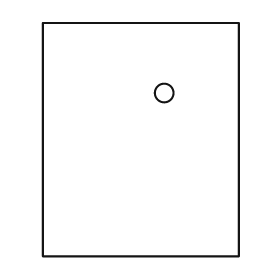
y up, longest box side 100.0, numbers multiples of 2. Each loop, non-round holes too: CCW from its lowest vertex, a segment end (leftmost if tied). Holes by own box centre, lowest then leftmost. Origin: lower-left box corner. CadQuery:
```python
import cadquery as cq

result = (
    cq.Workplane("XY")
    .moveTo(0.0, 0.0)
    .lineTo(84.0, 0.0)
    .lineTo(84.0, 100.0)
    .lineTo(0.0, 100.0)
    .close()
    .moveTo(52.0, 70.0)
    .circle(4.0)
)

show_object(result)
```